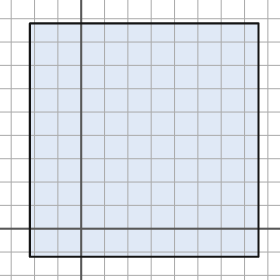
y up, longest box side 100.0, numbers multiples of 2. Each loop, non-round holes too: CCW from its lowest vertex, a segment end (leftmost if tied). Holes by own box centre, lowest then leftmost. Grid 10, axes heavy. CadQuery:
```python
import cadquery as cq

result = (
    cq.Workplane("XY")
    .moveTo(-22.0, -12.0)
    .lineTo(76.0, -12.0)
    .lineTo(76.0, 88.0)
    .lineTo(-22.0, 88.0)
    .close()
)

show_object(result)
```